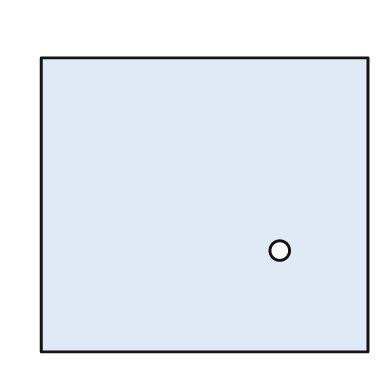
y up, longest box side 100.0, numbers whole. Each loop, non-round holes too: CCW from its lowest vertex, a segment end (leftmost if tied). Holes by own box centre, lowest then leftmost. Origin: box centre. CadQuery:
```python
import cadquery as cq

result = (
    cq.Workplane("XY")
    .moveTo(-50.0, -45.0)
    .lineTo(50.0, -45.0)
    .lineTo(50.0, 45.0)
    .lineTo(-50.0, 45.0)
    .close()
    .moveTo(23.0, -14.0)
    .circle(3.0)
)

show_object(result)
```